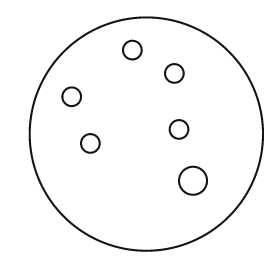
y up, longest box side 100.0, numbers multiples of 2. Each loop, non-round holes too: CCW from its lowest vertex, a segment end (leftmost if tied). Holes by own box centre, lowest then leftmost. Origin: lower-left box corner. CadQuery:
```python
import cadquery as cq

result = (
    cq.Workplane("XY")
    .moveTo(50.0, 50.0)
    .circle(50.0)
    .moveTo(70.0, 30.0)
    .circle(6.0)
    .moveTo(26.0, 46.0)
    .circle(4.0)
    .moveTo(64.0, 52.0)
    .circle(4.0)
    .moveTo(18.0, 66.0)
    .circle(4.0)
    .moveTo(62.0, 76.0)
    .circle(4.0)
    .moveTo(44.0, 86.0)
    .circle(4.0)
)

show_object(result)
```